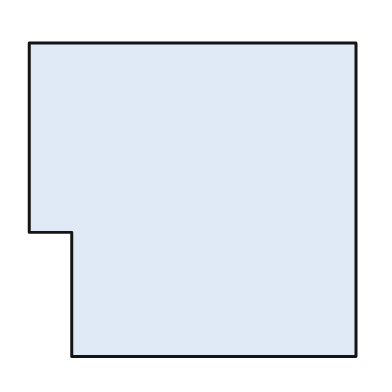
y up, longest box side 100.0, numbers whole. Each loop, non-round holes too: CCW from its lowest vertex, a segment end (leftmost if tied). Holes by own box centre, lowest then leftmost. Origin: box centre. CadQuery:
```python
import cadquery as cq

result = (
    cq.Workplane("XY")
    .moveTo(-37.0, -48.0)
    .lineTo(50.0, -48.0)
    .lineTo(50.0, 48.0)
    .lineTo(-50.0, 48.0)
    .lineTo(-50.0, -10.0)
    .lineTo(-37.0, -10.0)
    .close()
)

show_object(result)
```